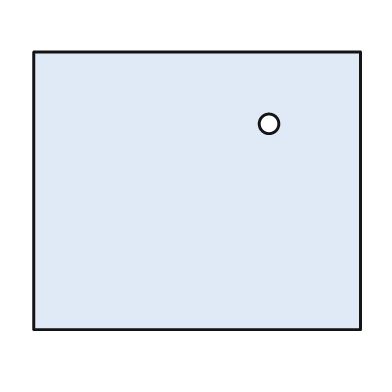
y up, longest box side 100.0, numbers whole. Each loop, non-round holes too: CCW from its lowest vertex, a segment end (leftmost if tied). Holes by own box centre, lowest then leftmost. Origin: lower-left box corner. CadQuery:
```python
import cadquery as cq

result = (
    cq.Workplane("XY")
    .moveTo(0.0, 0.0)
    .lineTo(100.0, 0.0)
    .lineTo(100.0, 85.0)
    .lineTo(0.0, 85.0)
    .close()
    .moveTo(72.0, 63.0)
    .circle(3.0)
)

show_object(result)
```